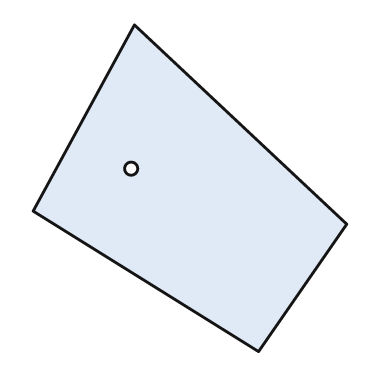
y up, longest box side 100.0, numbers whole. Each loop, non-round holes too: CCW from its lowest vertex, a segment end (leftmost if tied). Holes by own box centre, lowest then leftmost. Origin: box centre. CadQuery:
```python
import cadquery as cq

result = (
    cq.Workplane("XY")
    .moveTo(21.0, -50.0)
    .lineTo(48.0, -11.0)
    .lineTo(-17.0, 50.0)
    .lineTo(-48.0, -7.0)
    .close()
    .moveTo(-18.0, 6.0)
    .circle(2.0)
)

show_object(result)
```